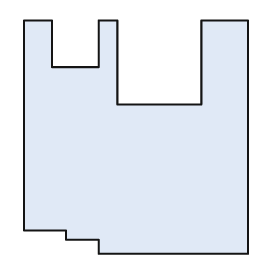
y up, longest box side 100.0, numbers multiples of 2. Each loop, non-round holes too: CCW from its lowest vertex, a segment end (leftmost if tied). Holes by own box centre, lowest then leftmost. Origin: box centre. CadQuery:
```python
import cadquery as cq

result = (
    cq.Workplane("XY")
    .moveTo(-16.0, -50.0)
    .lineTo(48.0, -50.0)
    .lineTo(48.0, 50.0)
    .lineTo(28.0, 50.0)
    .lineTo(28.0, 14.0)
    .lineTo(-8.0, 14.0)
    .lineTo(-8.0, 50.0)
    .lineTo(-16.0, 50.0)
    .lineTo(-16.0, 30.0)
    .lineTo(-36.0, 30.0)
    .lineTo(-36.0, 50.0)
    .lineTo(-48.0, 50.0)
    .lineTo(-48.0, -40.0)
    .lineTo(-30.0, -40.0)
    .lineTo(-30.0, -44.0)
    .lineTo(-16.0, -44.0)
    .close()
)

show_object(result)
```